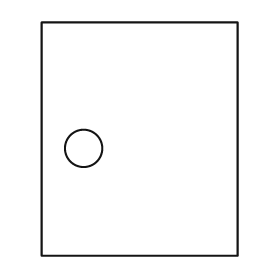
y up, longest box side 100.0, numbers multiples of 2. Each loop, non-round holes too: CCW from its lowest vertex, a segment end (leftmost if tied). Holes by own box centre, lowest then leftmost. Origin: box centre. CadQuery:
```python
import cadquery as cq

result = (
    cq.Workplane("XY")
    .moveTo(-42.0, -50.0)
    .lineTo(42.0, -50.0)
    .lineTo(42.0, 50.0)
    .lineTo(-42.0, 50.0)
    .close()
    .moveTo(-24.0, -4.0)
    .circle(8.0)
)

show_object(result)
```